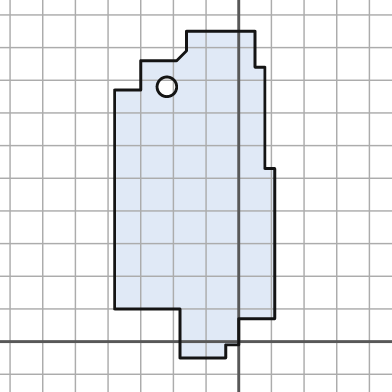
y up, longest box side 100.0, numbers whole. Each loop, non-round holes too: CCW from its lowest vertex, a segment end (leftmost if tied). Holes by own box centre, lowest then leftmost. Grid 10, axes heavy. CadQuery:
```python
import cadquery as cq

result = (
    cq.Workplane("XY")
    .moveTo(-18.0, -5.0)
    .lineTo(-4.0, -5.0)
    .lineTo(-4.0, -1.0)
    .lineTo(0.0, -1.0)
    .lineTo(0.0, 7.0)
    .lineTo(11.0, 7.0)
    .lineTo(11.0, 53.0)
    .lineTo(8.0, 53.0)
    .lineTo(8.0, 84.0)
    .lineTo(5.0, 84.0)
    .lineTo(5.0, 95.0)
    .lineTo(-16.0, 95.0)
    .lineTo(-16.0, 89.0)
    .lineTo(-19.0, 86.0)
    .lineTo(-30.0, 86.0)
    .lineTo(-30.0, 77.0)
    .lineTo(-38.0, 77.0)
    .lineTo(-38.0, 10.0)
    .lineTo(-18.0, 10.0)
    .close()
    .moveTo(-22.0, 78.0)
    .circle(3.0)
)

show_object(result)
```